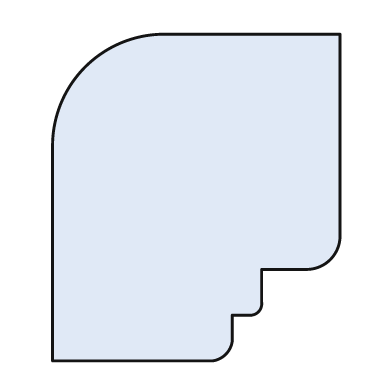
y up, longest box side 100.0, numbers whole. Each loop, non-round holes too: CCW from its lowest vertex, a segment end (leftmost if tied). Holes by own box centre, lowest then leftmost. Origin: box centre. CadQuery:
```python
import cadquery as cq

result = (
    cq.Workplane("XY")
    .moveTo(-44.0, -50.0)
    .lineTo(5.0, -50.0)
    .threePointArc((9.0, -48.0), (11.0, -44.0))
    .lineTo(11.0, -36.0)
    .lineTo(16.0, -36.0)
    .threePointArc((19.0, -35.0), (20.0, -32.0))
    .lineTo(20.0, -22.0)
    .lineTo(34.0, -22.0)
    .threePointArc((41.0, -19.0), (44.0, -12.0))
    .lineTo(44.0, 50.0)
    .lineTo(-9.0, 50.0)
    .threePointArc((-34.0, 40.0), (-44.0, 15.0))
    .close()
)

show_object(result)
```